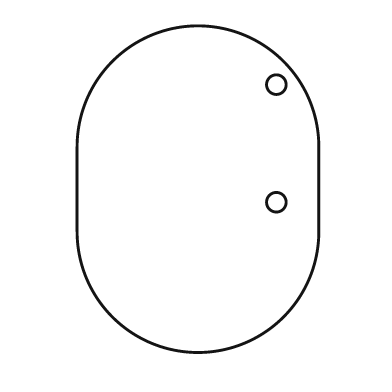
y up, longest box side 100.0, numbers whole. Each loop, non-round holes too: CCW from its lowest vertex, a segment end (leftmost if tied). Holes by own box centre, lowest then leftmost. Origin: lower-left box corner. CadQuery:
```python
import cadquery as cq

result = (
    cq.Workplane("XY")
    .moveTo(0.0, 37.0)
    .threePointArc((37.0, 0.0), (74.0, 37.0))
    .lineTo(74.0, 63.0)
    .threePointArc((37.0, 100.0), (0.0, 63.0))
    .close()
    .moveTo(61.0, 46.0)
    .circle(3.0)
    .moveTo(61.0, 82.0)
    .circle(3.0)
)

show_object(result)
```